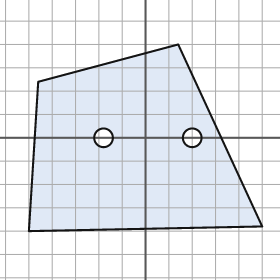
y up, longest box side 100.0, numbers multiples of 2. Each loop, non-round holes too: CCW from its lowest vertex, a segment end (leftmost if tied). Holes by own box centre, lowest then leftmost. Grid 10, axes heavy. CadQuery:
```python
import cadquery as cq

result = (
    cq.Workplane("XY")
    .moveTo(-50.0, -40.0)
    .lineTo(50.0, -38.0)
    .lineTo(14.0, 40.0)
    .lineTo(-46.0, 24.0)
    .close()
    .moveTo(-18.0, 0.0)
    .circle(4.0)
    .moveTo(20.0, 0.0)
    .circle(4.0)
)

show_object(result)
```